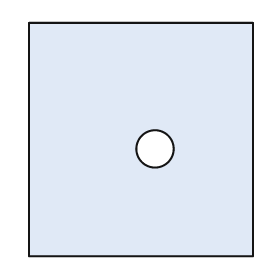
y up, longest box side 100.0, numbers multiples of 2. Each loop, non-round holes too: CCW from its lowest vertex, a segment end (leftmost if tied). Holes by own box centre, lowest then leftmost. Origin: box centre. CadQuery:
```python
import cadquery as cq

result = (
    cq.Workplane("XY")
    .moveTo(-48.0, -50.0)
    .lineTo(48.0, -50.0)
    .lineTo(48.0, 50.0)
    .lineTo(-48.0, 50.0)
    .close()
    .moveTo(6.0, -4.0)
    .circle(8.0)
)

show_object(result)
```